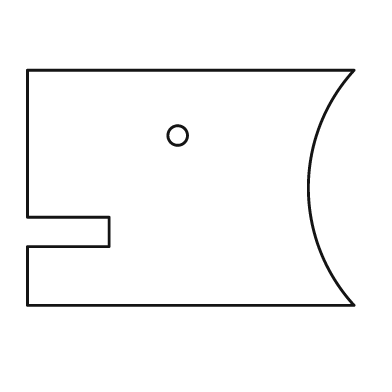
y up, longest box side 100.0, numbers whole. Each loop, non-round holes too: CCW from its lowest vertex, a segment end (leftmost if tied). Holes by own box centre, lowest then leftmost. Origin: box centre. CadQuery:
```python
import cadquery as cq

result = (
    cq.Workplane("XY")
    .moveTo(-50.0, -36.0)
    .lineTo(50.0, -36.0)
    .threePointArc((36.0, 0.0), (50.0, 36.0))
    .lineTo(-50.0, 36.0)
    .lineTo(-50.0, -9.0)
    .lineTo(-25.0, -9.0)
    .lineTo(-25.0, -18.0)
    .lineTo(-50.0, -18.0)
    .close()
    .moveTo(-4.0, 16.0)
    .circle(3.0)
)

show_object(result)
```